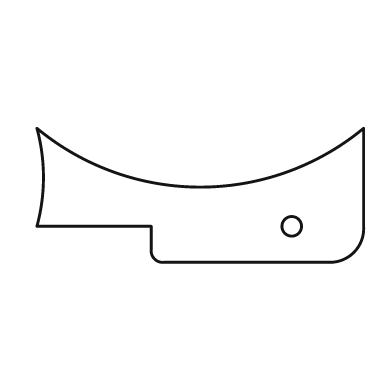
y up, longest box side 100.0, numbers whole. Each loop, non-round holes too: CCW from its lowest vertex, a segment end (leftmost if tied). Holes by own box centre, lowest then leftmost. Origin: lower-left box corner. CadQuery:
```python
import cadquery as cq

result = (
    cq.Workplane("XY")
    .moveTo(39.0, 0.0)
    .lineTo(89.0, 0.0)
    .threePointArc((97.0, 3.0), (100.0, 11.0))
    .lineTo(100.0, 41.0)
    .threePointArc((50.0, 23.0), (0.0, 41.0))
    .threePointArc((2.0, 26.0), (0.0, 11.0))
    .lineTo(35.0, 11.0)
    .lineTo(35.0, 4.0)
    .threePointArc((36.0, 1.0), (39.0, 0.0))
    .close()
    .moveTo(78.0, 11.0)
    .circle(3.0)
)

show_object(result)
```